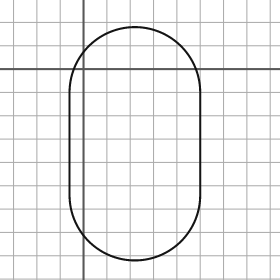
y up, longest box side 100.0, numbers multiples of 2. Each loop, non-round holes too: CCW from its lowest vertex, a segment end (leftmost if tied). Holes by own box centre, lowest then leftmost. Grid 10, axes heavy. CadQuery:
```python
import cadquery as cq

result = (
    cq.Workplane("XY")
    .moveTo(-6.0, -54.0)
    .threePointArc((22.0, -82.0), (50.0, -54.0))
    .lineTo(50.0, -10.0)
    .threePointArc((22.0, 18.0), (-6.0, -10.0))
    .close()
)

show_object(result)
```